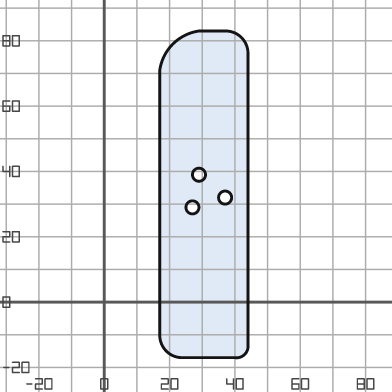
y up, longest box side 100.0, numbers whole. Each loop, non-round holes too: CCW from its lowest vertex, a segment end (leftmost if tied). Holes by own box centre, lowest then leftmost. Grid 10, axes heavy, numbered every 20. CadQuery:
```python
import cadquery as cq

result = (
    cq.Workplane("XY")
    .moveTo(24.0, -17.0)
    .lineTo(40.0, -17.0)
    .threePointArc((43.0, -16.0), (44.0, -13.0))
    .lineTo(44.0, 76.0)
    .threePointArc((42.0, 81.0), (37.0, 83.0))
    .lineTo(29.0, 83.0)
    .threePointArc((21.0, 79.0), (17.0, 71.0))
    .lineTo(17.0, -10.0)
    .threePointArc((19.0, -15.0), (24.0, -17.0))
    .close()
    .moveTo(27.0, 29.0)
    .circle(2.0)
    .moveTo(37.0, 32.0)
    .circle(2.0)
    .moveTo(29.0, 39.0)
    .circle(2.0)
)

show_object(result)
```